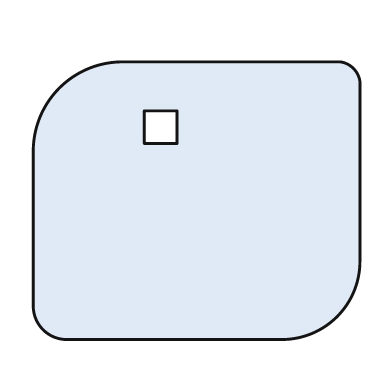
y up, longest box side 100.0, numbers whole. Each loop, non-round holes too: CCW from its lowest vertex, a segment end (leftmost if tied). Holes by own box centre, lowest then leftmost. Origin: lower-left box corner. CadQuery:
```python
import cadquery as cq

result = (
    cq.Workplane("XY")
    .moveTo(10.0, 0.0)
    .lineTo(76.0, 0.0)
    .threePointArc((93.0, 7.0), (100.0, 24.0))
    .lineTo(100.0, 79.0)
    .threePointArc((98.0, 83.0), (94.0, 85.0))
    .lineTo(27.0, 85.0)
    .threePointArc((8.0, 77.0), (0.0, 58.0))
    .lineTo(0.0, 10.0)
    .threePointArc((3.0, 3.0), (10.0, 0.0))
    .close()
    .moveTo(34.0, 60.0)
    .lineTo(44.0, 60.0)
    .lineTo(44.0, 70.0)
    .lineTo(34.0, 70.0)
    .close()
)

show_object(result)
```